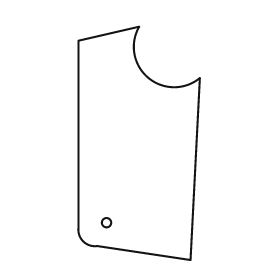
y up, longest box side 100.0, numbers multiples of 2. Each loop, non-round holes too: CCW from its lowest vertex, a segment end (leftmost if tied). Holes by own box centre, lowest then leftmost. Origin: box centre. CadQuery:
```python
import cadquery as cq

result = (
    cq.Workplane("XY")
    .moveTo(22.0, -50.0)
    .lineTo(26.0, 28.0)
    .threePointArc((4.0, 28.0), (0.0, 50.0))
    .lineTo(-26.0, 44.0)
    .lineTo(-26.0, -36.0)
    .threePointArc((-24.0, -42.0), (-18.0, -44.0))
    .close()
    .moveTo(-14.0, -34.0)
    .circle(2.0)
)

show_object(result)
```